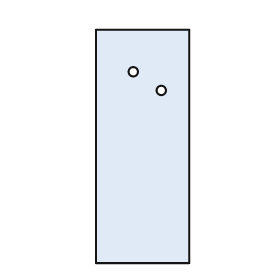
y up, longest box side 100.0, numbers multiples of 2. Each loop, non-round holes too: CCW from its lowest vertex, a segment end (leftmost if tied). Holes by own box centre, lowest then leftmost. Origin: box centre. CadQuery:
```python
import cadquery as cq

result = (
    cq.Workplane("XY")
    .moveTo(-20.0, -50.0)
    .lineTo(20.0, -50.0)
    .lineTo(20.0, 50.0)
    .lineTo(-20.0, 50.0)
    .close()
    .moveTo(8.0, 24.0)
    .circle(2.0)
    .moveTo(-4.0, 32.0)
    .circle(2.0)
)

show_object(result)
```